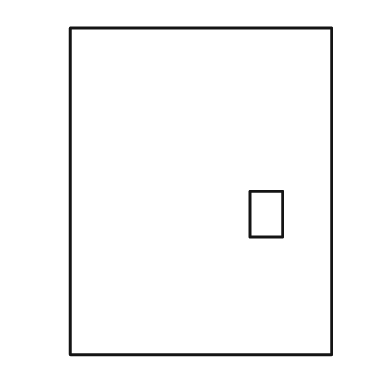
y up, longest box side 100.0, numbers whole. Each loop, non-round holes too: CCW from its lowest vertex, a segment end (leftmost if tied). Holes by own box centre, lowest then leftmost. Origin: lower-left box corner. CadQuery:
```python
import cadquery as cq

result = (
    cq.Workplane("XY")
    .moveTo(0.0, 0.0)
    .lineTo(80.0, 0.0)
    .lineTo(80.0, 100.0)
    .lineTo(0.0, 100.0)
    .close()
    .moveTo(55.0, 36.0)
    .lineTo(65.0, 36.0)
    .lineTo(65.0, 50.0)
    .lineTo(55.0, 50.0)
    .close()
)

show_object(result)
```